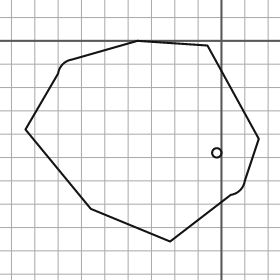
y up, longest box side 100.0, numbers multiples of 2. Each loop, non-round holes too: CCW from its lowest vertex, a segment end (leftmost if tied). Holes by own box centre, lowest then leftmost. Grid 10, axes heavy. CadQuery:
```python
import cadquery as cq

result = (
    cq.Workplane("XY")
    .moveTo(-22.0, -86.0)
    .lineTo(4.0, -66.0)
    .threePointArc((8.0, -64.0), (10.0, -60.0))
    .lineTo(16.0, -42.0)
    .lineTo(-6.0, -2.0)
    .lineTo(-36.0, 0.0)
    .lineTo(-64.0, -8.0)
    .threePointArc((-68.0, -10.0), (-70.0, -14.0))
    .lineTo(-84.0, -38.0)
    .lineTo(-56.0, -72.0)
    .close()
    .moveTo(-2.0, -48.0)
    .circle(2.0)
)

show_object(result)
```